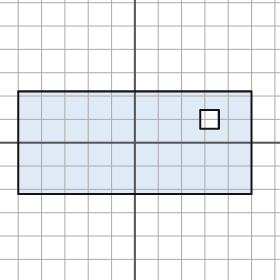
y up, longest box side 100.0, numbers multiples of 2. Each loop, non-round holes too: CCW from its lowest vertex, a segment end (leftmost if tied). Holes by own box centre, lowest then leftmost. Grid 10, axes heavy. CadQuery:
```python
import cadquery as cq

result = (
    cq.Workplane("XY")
    .moveTo(-50.0, -22.0)
    .lineTo(50.0, -22.0)
    .lineTo(50.0, 22.0)
    .lineTo(-50.0, 22.0)
    .close()
    .moveTo(28.0, 6.0)
    .lineTo(36.0, 6.0)
    .lineTo(36.0, 14.0)
    .lineTo(28.0, 14.0)
    .close()
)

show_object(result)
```